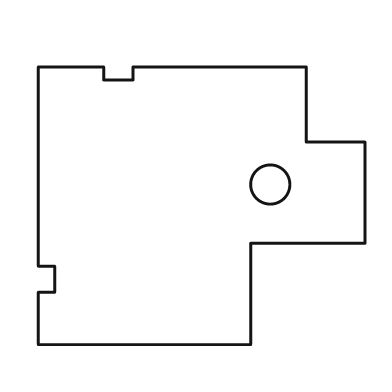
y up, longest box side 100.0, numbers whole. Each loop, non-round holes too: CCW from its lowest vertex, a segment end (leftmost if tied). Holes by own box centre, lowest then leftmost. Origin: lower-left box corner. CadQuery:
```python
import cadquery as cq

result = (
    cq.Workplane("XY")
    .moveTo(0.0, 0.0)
    .lineTo(65.0, 0.0)
    .lineTo(65.0, 31.0)
    .lineTo(100.0, 31.0)
    .lineTo(100.0, 62.0)
    .lineTo(82.0, 62.0)
    .lineTo(82.0, 85.0)
    .lineTo(29.0, 85.0)
    .lineTo(29.0, 81.0)
    .lineTo(20.0, 81.0)
    .lineTo(20.0, 85.0)
    .lineTo(0.0, 85.0)
    .lineTo(0.0, 24.0)
    .lineTo(5.0, 24.0)
    .lineTo(5.0, 16.0)
    .lineTo(0.0, 16.0)
    .close()
    .moveTo(71.0, 49.0)
    .circle(6.0)
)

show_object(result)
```